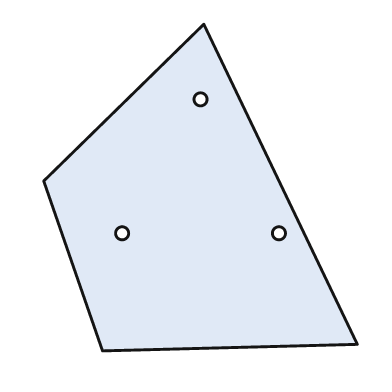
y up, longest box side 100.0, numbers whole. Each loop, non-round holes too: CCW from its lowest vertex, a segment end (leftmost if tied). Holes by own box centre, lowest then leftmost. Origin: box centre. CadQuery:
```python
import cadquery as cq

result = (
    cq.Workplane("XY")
    .moveTo(-30.0, -50.0)
    .lineTo(48.0, -48.0)
    .lineTo(1.0, 50.0)
    .lineTo(-48.0, 2.0)
    .close()
    .moveTo(-24.0, -14.0)
    .circle(2.0)
    .moveTo(24.0, -14.0)
    .circle(2.0)
    .moveTo(0.0, 27.0)
    .circle(2.0)
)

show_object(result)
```